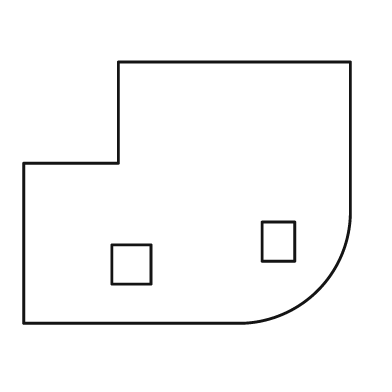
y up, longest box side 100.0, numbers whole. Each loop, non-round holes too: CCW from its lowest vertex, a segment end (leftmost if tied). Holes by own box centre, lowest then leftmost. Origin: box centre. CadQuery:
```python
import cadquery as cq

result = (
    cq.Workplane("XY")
    .moveTo(-50.0, -40.0)
    .lineTo(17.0, -40.0)
    .threePointArc((40.0, -30.0), (50.0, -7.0))
    .lineTo(50.0, 40.0)
    .lineTo(-21.0, 40.0)
    .lineTo(-21.0, 9.0)
    .lineTo(-50.0, 9.0)
    .close()
    .moveTo(-23.0, -28.0)
    .lineTo(-11.0, -28.0)
    .lineTo(-11.0, -16.0)
    .lineTo(-23.0, -16.0)
    .close()
    .moveTo(23.0, -21.0)
    .lineTo(33.0, -21.0)
    .lineTo(33.0, -9.0)
    .lineTo(23.0, -9.0)
    .close()
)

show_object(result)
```